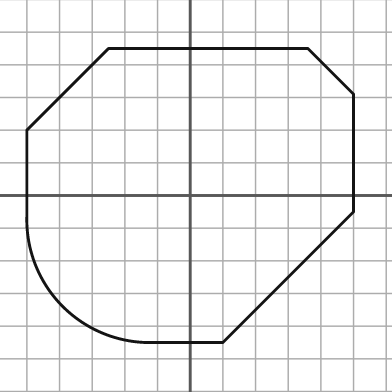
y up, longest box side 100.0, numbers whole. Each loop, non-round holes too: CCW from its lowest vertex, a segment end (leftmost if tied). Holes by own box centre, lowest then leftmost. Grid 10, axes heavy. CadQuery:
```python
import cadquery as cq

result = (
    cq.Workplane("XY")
    .moveTo(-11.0, -45.0)
    .lineTo(10.0, -45.0)
    .lineTo(50.0, -5.0)
    .lineTo(50.0, 31.0)
    .lineTo(36.0, 45.0)
    .lineTo(-25.0, 45.0)
    .lineTo(-50.0, 20.0)
    .lineTo(-50.0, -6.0)
    .threePointArc((-39.0, -34.0), (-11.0, -45.0))
    .close()
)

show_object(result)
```